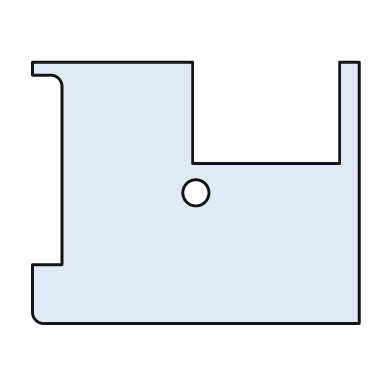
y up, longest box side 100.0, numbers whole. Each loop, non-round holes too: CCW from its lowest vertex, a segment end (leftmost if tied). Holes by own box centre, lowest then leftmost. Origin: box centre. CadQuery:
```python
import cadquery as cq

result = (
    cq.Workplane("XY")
    .moveTo(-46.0, -40.0)
    .lineTo(50.0, -40.0)
    .lineTo(50.0, 40.0)
    .lineTo(44.0, 40.0)
    .lineTo(44.0, 9.0)
    .lineTo(-1.0, 9.0)
    .lineTo(-1.0, 40.0)
    .lineTo(-50.0, 40.0)
    .lineTo(-50.0, 36.0)
    .lineTo(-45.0, 36.0)
    .threePointArc((-42.0, 35.0), (-41.0, 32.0))
    .lineTo(-41.0, -22.0)
    .lineTo(-50.0, -22.0)
    .lineTo(-50.0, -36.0)
    .threePointArc((-49.0, -39.0), (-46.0, -40.0))
    .close()
    .moveTo(0.0, 0.0)
    .circle(4.0)
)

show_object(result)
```